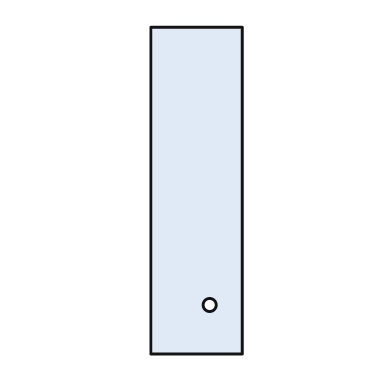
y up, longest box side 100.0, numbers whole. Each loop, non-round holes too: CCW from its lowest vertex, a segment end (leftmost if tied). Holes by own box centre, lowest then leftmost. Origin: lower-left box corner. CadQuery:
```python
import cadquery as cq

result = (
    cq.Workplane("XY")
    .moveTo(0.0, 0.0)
    .lineTo(28.0, 0.0)
    .lineTo(28.0, 100.0)
    .lineTo(0.0, 100.0)
    .close()
    .moveTo(18.0, 15.0)
    .circle(2.0)
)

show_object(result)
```